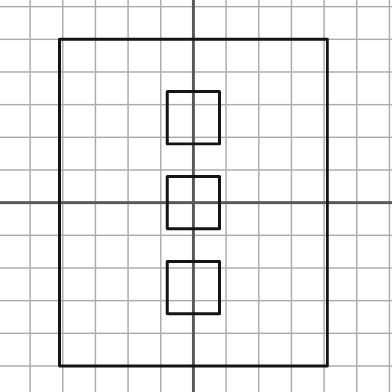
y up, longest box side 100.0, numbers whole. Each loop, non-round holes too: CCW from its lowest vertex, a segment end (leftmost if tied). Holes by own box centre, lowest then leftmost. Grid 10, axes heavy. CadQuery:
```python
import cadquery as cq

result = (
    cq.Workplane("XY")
    .moveTo(-41.0, -50.0)
    .lineTo(41.0, -50.0)
    .lineTo(41.0, 50.0)
    .lineTo(-41.0, 50.0)
    .close()
    .moveTo(-8.0, -34.0)
    .lineTo(8.0, -34.0)
    .lineTo(8.0, -18.0)
    .lineTo(-8.0, -18.0)
    .close()
    .moveTo(-8.0, -8.0)
    .lineTo(8.0, -8.0)
    .lineTo(8.0, 8.0)
    .lineTo(-8.0, 8.0)
    .close()
    .moveTo(-8.0, 18.0)
    .lineTo(8.0, 18.0)
    .lineTo(8.0, 34.0)
    .lineTo(-8.0, 34.0)
    .close()
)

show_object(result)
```